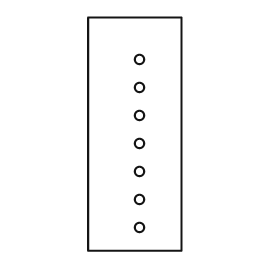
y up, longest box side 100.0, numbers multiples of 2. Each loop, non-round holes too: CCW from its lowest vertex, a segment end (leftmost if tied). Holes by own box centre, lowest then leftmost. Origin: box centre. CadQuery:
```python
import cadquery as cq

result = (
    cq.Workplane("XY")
    .moveTo(-20.0, -50.0)
    .lineTo(20.0, -50.0)
    .lineTo(20.0, 50.0)
    .lineTo(-20.0, 50.0)
    .close()
    .moveTo(2.0, -40.0)
    .circle(2.0)
    .moveTo(2.0, -28.0)
    .circle(2.0)
    .moveTo(2.0, -16.0)
    .circle(2.0)
    .moveTo(2.0, -4.0)
    .circle(2.0)
    .moveTo(2.0, 8.0)
    .circle(2.0)
    .moveTo(2.0, 20.0)
    .circle(2.0)
    .moveTo(2.0, 32.0)
    .circle(2.0)
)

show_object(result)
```